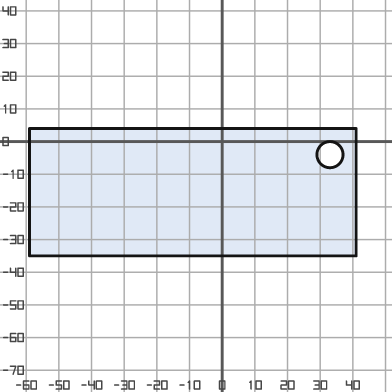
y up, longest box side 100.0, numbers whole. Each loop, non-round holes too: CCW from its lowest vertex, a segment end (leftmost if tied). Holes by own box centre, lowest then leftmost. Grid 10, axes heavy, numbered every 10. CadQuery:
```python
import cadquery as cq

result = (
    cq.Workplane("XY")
    .moveTo(-59.0, -35.0)
    .lineTo(41.0, -35.0)
    .lineTo(41.0, 4.0)
    .lineTo(-59.0, 4.0)
    .close()
    .moveTo(33.0, -4.0)
    .circle(4.0)
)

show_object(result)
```